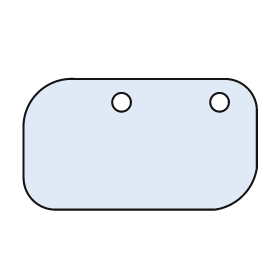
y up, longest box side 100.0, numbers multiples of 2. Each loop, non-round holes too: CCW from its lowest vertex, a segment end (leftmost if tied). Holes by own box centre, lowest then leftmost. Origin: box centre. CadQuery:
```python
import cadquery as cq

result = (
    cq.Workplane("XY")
    .moveTo(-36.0, -28.0)
    .lineTo(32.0, -28.0)
    .threePointArc((44.0, -22.0), (50.0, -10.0))
    .lineTo(50.0, 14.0)
    .threePointArc((46.0, 24.0), (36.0, 28.0))
    .lineTo(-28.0, 28.0)
    .threePointArc((-44.0, 22.0), (-50.0, 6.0))
    .lineTo(-50.0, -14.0)
    .threePointArc((-46.0, -24.0), (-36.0, -28.0))
    .close()
    .moveTo(-8.0, 18.0)
    .circle(4.0)
    .moveTo(34.0, 18.0)
    .circle(4.0)
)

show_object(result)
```